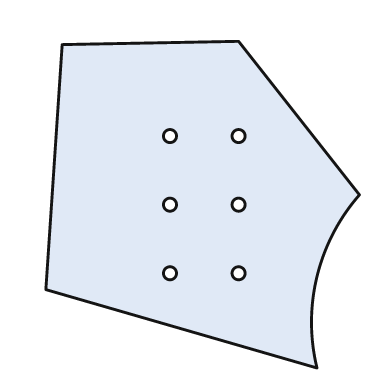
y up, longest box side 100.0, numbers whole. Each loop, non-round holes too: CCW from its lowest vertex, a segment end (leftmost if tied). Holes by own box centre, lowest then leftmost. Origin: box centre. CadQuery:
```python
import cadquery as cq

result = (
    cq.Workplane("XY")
    .moveTo(35.0, -50.0)
    .threePointArc((35.0, -22.0), (48.0, 3.0))
    .lineTo(11.0, 50.0)
    .lineTo(-43.0, 49.0)
    .lineTo(-48.0, -26.0)
    .close()
    .moveTo(-10.0, -21.0)
    .circle(2.0)
    .moveTo(11.0, -21.0)
    .circle(2.0)
    .moveTo(-10.0, 0.0)
    .circle(2.0)
    .moveTo(11.0, 0.0)
    .circle(2.0)
    .moveTo(-10.0, 21.0)
    .circle(2.0)
    .moveTo(11.0, 21.0)
    .circle(2.0)
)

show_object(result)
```